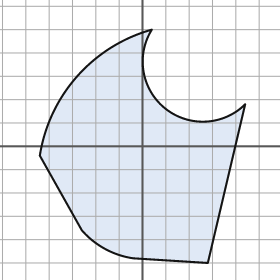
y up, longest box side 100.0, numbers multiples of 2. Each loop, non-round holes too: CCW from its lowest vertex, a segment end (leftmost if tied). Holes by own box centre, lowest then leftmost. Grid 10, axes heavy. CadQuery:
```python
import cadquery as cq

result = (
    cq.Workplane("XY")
    .moveTo(28.0, -50.0)
    .lineTo(44.0, 18.0)
    .threePointArc((10.0, 16.0), (4.0, 50.0))
    .threePointArc((-28.0, 30.0), (-44.0, -4.0))
    .lineTo(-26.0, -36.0)
    .threePointArc((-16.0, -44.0), (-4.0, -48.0))
    .close()
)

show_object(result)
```